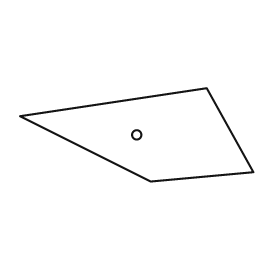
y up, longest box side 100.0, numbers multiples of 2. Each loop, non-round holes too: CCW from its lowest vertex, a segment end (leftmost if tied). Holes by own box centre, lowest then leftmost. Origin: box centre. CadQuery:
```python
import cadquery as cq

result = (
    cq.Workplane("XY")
    .moveTo(6.0, -20.0)
    .lineTo(50.0, -16.0)
    .lineTo(30.0, 20.0)
    .lineTo(-50.0, 8.0)
    .close()
    .moveTo(0.0, 0.0)
    .circle(2.0)
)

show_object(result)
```